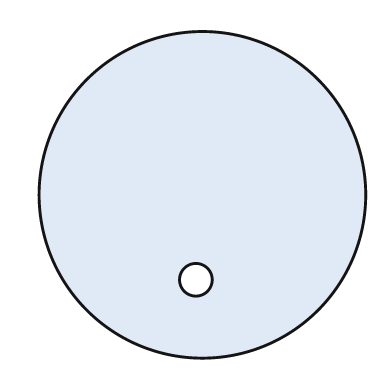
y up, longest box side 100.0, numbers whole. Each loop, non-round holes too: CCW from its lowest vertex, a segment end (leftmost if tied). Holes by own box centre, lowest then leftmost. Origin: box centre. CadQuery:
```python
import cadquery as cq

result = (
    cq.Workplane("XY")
    .moveTo(0.0, 0.0)
    .circle(50.0)
    .moveTo(-2.0, -26.0)
    .circle(5.0)
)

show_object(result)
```